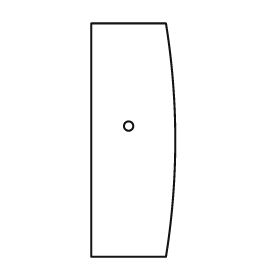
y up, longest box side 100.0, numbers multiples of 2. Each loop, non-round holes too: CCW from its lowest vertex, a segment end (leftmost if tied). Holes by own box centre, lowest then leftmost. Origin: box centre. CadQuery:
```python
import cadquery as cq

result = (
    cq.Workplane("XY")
    .moveTo(-18.0, -50.0)
    .lineTo(14.0, -50.0)
    .threePointArc((18.0, 0.0), (14.0, 50.0))
    .lineTo(-18.0, 50.0)
    .close()
    .moveTo(-2.0, 6.0)
    .circle(2.0)
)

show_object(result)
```